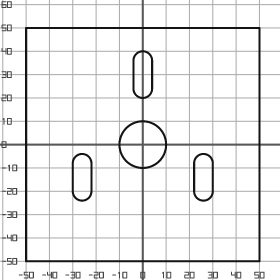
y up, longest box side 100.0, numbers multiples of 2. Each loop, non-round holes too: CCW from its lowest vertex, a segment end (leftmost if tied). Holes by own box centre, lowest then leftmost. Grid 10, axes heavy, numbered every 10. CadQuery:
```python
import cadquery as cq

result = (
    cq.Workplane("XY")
    .moveTo(-50.0, -50.0)
    .lineTo(50.0, -50.0)
    .lineTo(50.0, 50.0)
    .lineTo(-50.0, 50.0)
    .close()
    .moveTo(-30.0, -20.0)
    .threePointArc((-26.0, -24.0), (-22.0, -20.0))
    .lineTo(-22.0, -8.0)
    .threePointArc((-26.0, -4.0), (-30.0, -8.0))
    .close()
    .moveTo(22.0, -20.0)
    .threePointArc((26.0, -24.0), (30.0, -20.0))
    .lineTo(30.0, -8.0)
    .threePointArc((26.0, -4.0), (22.0, -8.0))
    .close()
    .moveTo(0.0, 0.0)
    .circle(10.0)
    .moveTo(-4.0, 24.0)
    .threePointArc((0.0, 20.0), (4.0, 24.0))
    .lineTo(4.0, 36.0)
    .threePointArc((0.0, 40.0), (-4.0, 36.0))
    .close()
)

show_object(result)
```